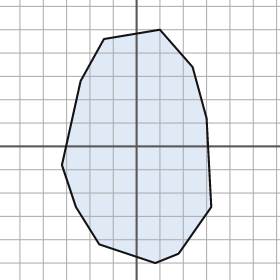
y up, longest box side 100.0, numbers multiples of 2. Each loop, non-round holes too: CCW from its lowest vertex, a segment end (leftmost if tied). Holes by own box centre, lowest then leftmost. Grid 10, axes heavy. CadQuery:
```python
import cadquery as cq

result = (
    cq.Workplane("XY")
    .moveTo(8.0, -50.0)
    .lineTo(18.0, -46.0)
    .lineTo(32.0, -26.0)
    .lineTo(30.0, 12.0)
    .lineTo(24.0, 34.0)
    .lineTo(10.0, 50.0)
    .lineTo(-14.0, 46.0)
    .lineTo(-24.0, 28.0)
    .lineTo(-32.0, -8.0)
    .lineTo(-26.0, -26.0)
    .lineTo(-16.0, -42.0)
    .close()
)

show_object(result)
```